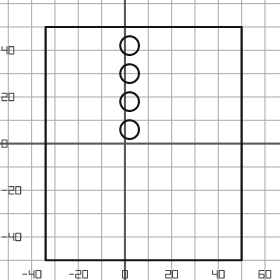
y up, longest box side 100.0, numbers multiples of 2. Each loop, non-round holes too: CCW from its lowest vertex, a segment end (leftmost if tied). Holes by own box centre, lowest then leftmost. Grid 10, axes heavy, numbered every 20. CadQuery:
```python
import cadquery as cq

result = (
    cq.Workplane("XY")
    .moveTo(-34.0, -50.0)
    .lineTo(50.0, -50.0)
    .lineTo(50.0, 50.0)
    .lineTo(-34.0, 50.0)
    .close()
    .moveTo(2.0, 6.0)
    .circle(4.0)
    .moveTo(2.0, 18.0)
    .circle(4.0)
    .moveTo(2.0, 30.0)
    .circle(4.0)
    .moveTo(2.0, 42.0)
    .circle(4.0)
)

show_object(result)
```